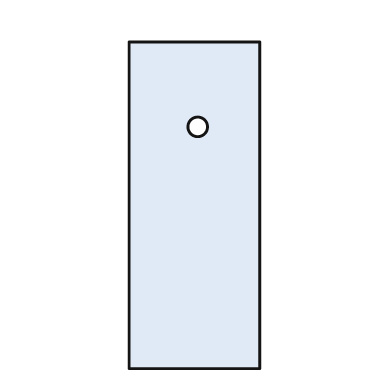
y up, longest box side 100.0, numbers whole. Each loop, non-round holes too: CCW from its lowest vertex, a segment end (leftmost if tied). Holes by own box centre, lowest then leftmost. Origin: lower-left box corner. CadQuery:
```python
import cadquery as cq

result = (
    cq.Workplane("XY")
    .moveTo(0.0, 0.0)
    .lineTo(40.0, 0.0)
    .lineTo(40.0, 100.0)
    .lineTo(0.0, 100.0)
    .close()
    .moveTo(21.0, 74.0)
    .circle(3.0)
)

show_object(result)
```